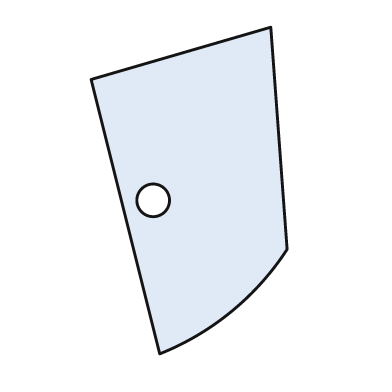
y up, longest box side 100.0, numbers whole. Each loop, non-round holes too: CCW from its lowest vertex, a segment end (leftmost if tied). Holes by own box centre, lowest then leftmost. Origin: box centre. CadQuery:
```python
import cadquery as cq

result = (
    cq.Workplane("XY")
    .moveTo(-9.0, -50.0)
    .threePointArc((13.0, -37.0), (30.0, -18.0))
    .lineTo(25.0, 50.0)
    .lineTo(-30.0, 34.0)
    .close()
    .moveTo(-11.0, -3.0)
    .circle(5.0)
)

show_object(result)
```